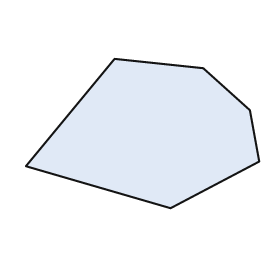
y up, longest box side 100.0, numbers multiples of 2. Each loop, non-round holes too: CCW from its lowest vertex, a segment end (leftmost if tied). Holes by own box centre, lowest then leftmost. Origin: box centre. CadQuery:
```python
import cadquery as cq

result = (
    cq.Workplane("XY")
    .moveTo(12.0, -32.0)
    .lineTo(50.0, -12.0)
    .lineTo(46.0, 10.0)
    .lineTo(26.0, 28.0)
    .lineTo(-12.0, 32.0)
    .lineTo(-50.0, -14.0)
    .close()
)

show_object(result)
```